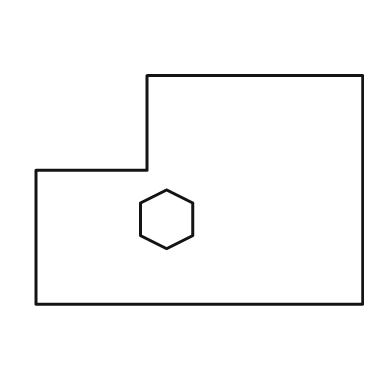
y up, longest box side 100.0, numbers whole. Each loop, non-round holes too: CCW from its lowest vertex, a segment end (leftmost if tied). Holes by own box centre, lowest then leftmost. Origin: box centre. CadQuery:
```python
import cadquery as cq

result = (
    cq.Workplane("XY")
    .moveTo(-50.0, -35.0)
    .lineTo(50.0, -35.0)
    .lineTo(50.0, 35.0)
    .lineTo(-16.0, 35.0)
    .lineTo(-16.0, 6.0)
    .lineTo(-50.0, 6.0)
    .close()
    .moveTo(-10.0, -18.0)
    .lineTo(-2.0, -14.0)
    .lineTo(-2.0, -4.0)
    .lineTo(-10.0, 0.0)
    .lineTo(-18.0, -4.0)
    .lineTo(-18.0, -14.0)
    .close()
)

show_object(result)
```